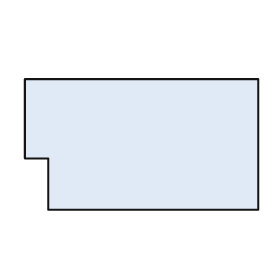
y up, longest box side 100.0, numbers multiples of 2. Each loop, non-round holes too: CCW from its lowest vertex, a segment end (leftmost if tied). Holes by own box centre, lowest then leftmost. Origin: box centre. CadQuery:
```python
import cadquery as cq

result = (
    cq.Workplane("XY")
    .moveTo(-40.0, -28.0)
    .lineTo(50.0, -28.0)
    .lineTo(50.0, 28.0)
    .lineTo(-50.0, 28.0)
    .lineTo(-50.0, -6.0)
    .lineTo(-40.0, -6.0)
    .close()
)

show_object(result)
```